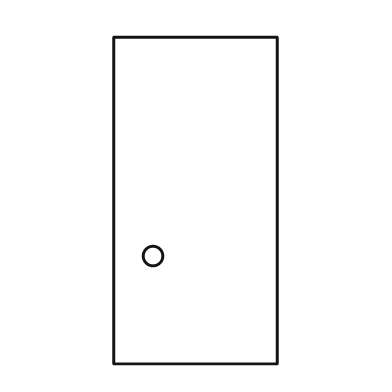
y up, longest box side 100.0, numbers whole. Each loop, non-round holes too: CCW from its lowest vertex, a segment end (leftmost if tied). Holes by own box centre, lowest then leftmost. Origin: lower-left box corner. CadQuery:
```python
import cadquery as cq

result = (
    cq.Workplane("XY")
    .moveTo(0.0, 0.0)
    .lineTo(50.0, 0.0)
    .lineTo(50.0, 100.0)
    .lineTo(0.0, 100.0)
    .close()
    .moveTo(12.0, 33.0)
    .circle(3.0)
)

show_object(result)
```